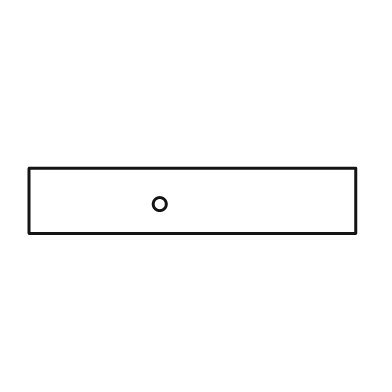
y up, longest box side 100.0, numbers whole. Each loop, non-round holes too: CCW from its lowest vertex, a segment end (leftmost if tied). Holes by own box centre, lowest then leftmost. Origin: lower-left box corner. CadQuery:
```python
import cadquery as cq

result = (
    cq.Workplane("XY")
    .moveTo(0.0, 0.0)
    .lineTo(100.0, 0.0)
    .lineTo(100.0, 20.0)
    .lineTo(0.0, 20.0)
    .close()
    .moveTo(40.0, 9.0)
    .circle(2.0)
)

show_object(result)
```